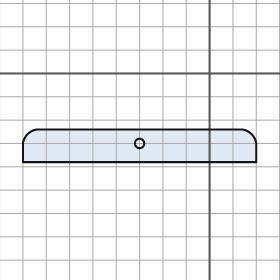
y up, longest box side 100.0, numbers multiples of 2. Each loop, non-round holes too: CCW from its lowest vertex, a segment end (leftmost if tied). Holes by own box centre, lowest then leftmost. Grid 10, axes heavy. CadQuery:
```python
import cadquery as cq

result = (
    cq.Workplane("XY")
    .moveTo(-80.0, -38.0)
    .lineTo(20.0, -38.0)
    .lineTo(20.0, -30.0)
    .threePointArc((18.0, -26.0), (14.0, -24.0))
    .lineTo(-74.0, -24.0)
    .threePointArc((-78.0, -26.0), (-80.0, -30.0))
    .close()
    .moveTo(-30.0, -30.0)
    .circle(2.0)
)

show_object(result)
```